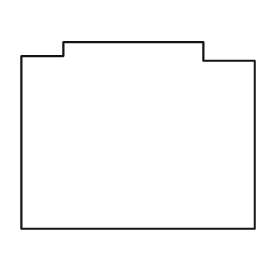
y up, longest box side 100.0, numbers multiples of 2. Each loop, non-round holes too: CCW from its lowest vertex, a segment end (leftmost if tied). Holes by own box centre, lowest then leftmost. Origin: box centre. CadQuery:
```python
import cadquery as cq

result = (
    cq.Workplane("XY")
    .moveTo(-50.0, -40.0)
    .lineTo(50.0, -40.0)
    .lineTo(50.0, 32.0)
    .lineTo(28.0, 32.0)
    .lineTo(28.0, 40.0)
    .lineTo(-32.0, 40.0)
    .lineTo(-32.0, 34.0)
    .lineTo(-50.0, 34.0)
    .close()
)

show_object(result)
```